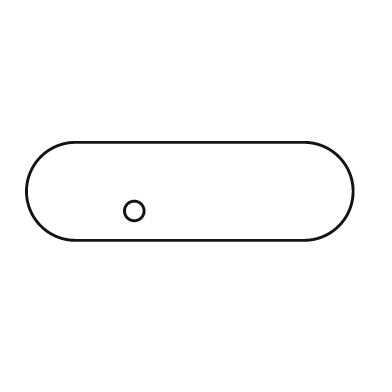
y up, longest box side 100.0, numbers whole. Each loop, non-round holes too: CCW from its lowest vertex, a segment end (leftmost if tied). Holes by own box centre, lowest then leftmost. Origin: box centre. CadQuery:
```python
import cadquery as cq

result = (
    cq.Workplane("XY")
    .moveTo(-35.0, -15.0)
    .lineTo(35.0, -15.0)
    .threePointArc((50.0, 0.0), (35.0, 15.0))
    .lineTo(-35.0, 15.0)
    .threePointArc((-50.0, 0.0), (-35.0, -15.0))
    .close()
    .moveTo(-17.0, -6.0)
    .circle(3.0)
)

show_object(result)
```